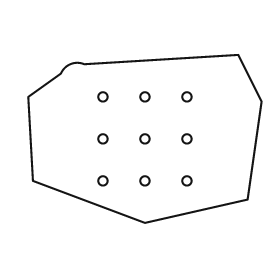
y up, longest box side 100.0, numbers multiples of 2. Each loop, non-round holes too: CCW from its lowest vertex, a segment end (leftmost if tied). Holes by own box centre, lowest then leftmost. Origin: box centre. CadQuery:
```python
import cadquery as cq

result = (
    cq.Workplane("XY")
    .moveTo(0.0, -36.0)
    .lineTo(44.0, -26.0)
    .lineTo(50.0, 16.0)
    .lineTo(40.0, 36.0)
    .lineTo(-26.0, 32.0)
    .threePointArc((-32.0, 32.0), (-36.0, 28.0))
    .lineTo(-50.0, 18.0)
    .lineTo(-48.0, -18.0)
    .close()
    .moveTo(-18.0, -18.0)
    .circle(2.0)
    .moveTo(0.0, -18.0)
    .circle(2.0)
    .moveTo(18.0, -18.0)
    .circle(2.0)
    .moveTo(-18.0, 0.0)
    .circle(2.0)
    .moveTo(0.0, 0.0)
    .circle(2.0)
    .moveTo(18.0, 0.0)
    .circle(2.0)
    .moveTo(-18.0, 18.0)
    .circle(2.0)
    .moveTo(0.0, 18.0)
    .circle(2.0)
    .moveTo(18.0, 18.0)
    .circle(2.0)
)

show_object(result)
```